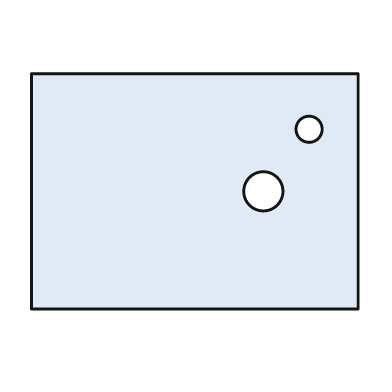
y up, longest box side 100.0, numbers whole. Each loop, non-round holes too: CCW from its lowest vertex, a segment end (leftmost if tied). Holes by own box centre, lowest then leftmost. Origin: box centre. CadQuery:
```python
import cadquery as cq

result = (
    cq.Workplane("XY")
    .moveTo(-50.0, -36.0)
    .lineTo(50.0, -36.0)
    .lineTo(50.0, 36.0)
    .lineTo(-50.0, 36.0)
    .close()
    .moveTo(21.0, 0.0)
    .circle(6.0)
    .moveTo(35.0, 19.0)
    .circle(4.0)
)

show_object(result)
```